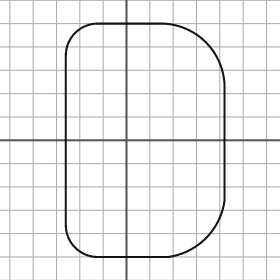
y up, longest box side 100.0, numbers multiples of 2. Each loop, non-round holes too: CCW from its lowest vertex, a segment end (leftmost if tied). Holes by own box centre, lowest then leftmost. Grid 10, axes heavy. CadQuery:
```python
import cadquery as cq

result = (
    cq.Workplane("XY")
    .moveTo(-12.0, -50.0)
    .lineTo(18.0, -50.0)
    .threePointArc((34.0, -42.0), (42.0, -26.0))
    .lineTo(42.0, 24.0)
    .threePointArc((34.0, 42.0), (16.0, 50.0))
    .lineTo(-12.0, 50.0)
    .threePointArc((-22.0, 46.0), (-26.0, 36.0))
    .lineTo(-26.0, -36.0)
    .threePointArc((-22.0, -46.0), (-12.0, -50.0))
    .close()
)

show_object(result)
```